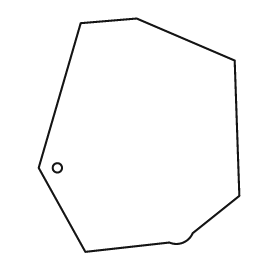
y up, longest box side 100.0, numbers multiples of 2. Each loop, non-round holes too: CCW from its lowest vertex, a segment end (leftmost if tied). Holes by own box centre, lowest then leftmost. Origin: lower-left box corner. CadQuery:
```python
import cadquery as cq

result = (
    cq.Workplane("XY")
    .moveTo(20.0, 0.0)
    .lineTo(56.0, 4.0)
    .threePointArc((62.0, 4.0), (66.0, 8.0))
    .lineTo(86.0, 24.0)
    .lineTo(84.0, 82.0)
    .lineTo(42.0, 100.0)
    .lineTo(18.0, 98.0)
    .lineTo(0.0, 36.0)
    .close()
    .moveTo(8.0, 36.0)
    .circle(2.0)
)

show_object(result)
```